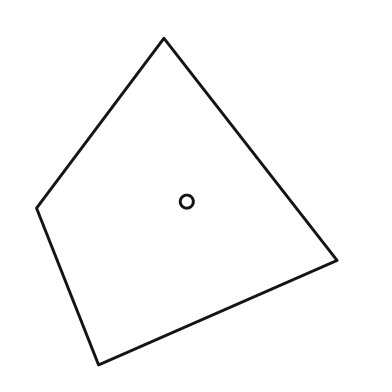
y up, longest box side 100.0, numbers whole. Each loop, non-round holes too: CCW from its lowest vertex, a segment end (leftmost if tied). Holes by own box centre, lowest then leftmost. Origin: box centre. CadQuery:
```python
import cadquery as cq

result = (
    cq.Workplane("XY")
    .moveTo(-27.0, -50.0)
    .lineTo(46.0, -18.0)
    .lineTo(-7.0, 50.0)
    .lineTo(-46.0, -2.0)
    .close()
    .moveTo(0.0, 0.0)
    .circle(2.0)
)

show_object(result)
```